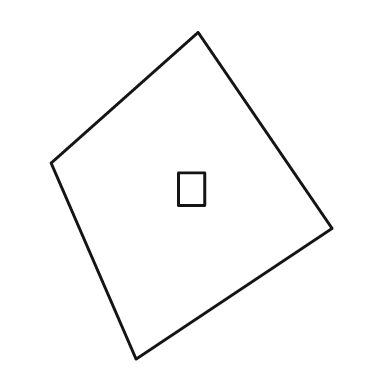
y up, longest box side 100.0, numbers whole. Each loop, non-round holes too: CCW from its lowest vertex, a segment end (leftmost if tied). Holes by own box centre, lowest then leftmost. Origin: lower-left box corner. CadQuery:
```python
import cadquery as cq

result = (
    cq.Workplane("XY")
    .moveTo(26.0, 0.0)
    .lineTo(86.0, 40.0)
    .lineTo(45.0, 100.0)
    .lineTo(0.0, 60.0)
    .close()
    .moveTo(39.0, 47.0)
    .lineTo(47.0, 47.0)
    .lineTo(47.0, 57.0)
    .lineTo(39.0, 57.0)
    .close()
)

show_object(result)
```